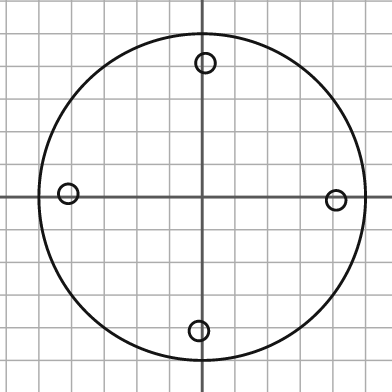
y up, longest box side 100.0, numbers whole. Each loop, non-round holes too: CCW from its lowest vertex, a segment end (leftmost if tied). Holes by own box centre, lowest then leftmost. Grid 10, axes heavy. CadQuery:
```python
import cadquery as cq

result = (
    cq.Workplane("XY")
    .moveTo(0.0, 0.0)
    .circle(50.0)
    .moveTo(-1.0, -41.0)
    .circle(3.0)
    .moveTo(41.0, -1.0)
    .circle(3.0)
    .moveTo(-41.0, 1.0)
    .circle(3.0)
    .moveTo(1.0, 41.0)
    .circle(3.0)
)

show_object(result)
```